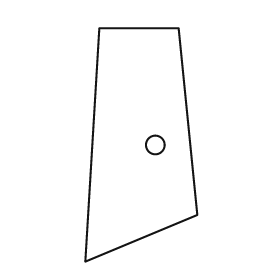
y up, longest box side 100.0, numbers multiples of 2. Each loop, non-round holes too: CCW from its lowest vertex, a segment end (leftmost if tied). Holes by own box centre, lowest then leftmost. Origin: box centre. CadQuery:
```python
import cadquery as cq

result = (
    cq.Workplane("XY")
    .moveTo(-24.0, -50.0)
    .lineTo(24.0, -30.0)
    .lineTo(16.0, 50.0)
    .lineTo(-18.0, 50.0)
    .close()
    .moveTo(6.0, 0.0)
    .circle(4.0)
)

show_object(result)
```